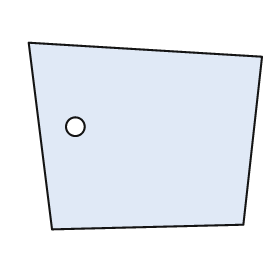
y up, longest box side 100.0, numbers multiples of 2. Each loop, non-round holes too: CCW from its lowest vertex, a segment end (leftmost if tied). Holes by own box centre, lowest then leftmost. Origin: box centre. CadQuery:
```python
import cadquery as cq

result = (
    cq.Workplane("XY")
    .moveTo(-40.0, -40.0)
    .lineTo(42.0, -38.0)
    .lineTo(50.0, 34.0)
    .lineTo(-50.0, 40.0)
    .close()
    .moveTo(-30.0, 4.0)
    .circle(4.0)
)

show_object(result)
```